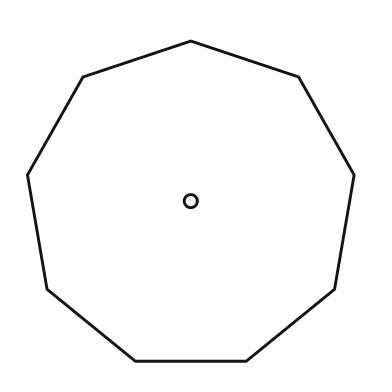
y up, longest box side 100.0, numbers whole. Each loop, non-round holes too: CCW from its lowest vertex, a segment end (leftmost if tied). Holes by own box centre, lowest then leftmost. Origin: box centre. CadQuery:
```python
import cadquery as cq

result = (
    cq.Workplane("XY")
    .moveTo(-17.0, -49.0)
    .lineTo(17.0, -49.0)
    .lineTo(44.0, -27.0)
    .lineTo(50.0, 8.0)
    .lineTo(33.0, 38.0)
    .lineTo(0.0, 49.0)
    .lineTo(-33.0, 38.0)
    .lineTo(-50.0, 8.0)
    .lineTo(-44.0, -27.0)
    .close()
    .moveTo(0.0, 0.0)
    .circle(2.0)
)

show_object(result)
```